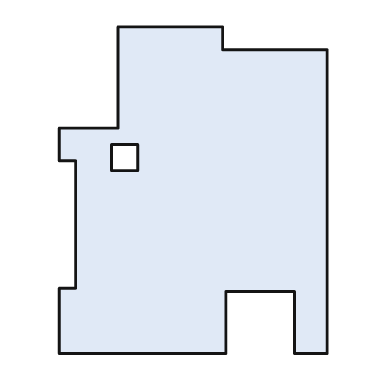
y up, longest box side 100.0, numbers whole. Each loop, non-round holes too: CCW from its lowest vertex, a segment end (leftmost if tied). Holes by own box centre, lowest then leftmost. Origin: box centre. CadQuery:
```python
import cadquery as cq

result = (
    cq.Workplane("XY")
    .moveTo(-41.0, -50.0)
    .lineTo(10.0, -50.0)
    .lineTo(10.0, -31.0)
    .lineTo(31.0, -31.0)
    .lineTo(31.0, -50.0)
    .lineTo(41.0, -50.0)
    .lineTo(41.0, 43.0)
    .lineTo(9.0, 43.0)
    .lineTo(9.0, 50.0)
    .lineTo(-23.0, 50.0)
    .lineTo(-23.0, 19.0)
    .lineTo(-41.0, 19.0)
    .lineTo(-41.0, 9.0)
    .lineTo(-36.0, 9.0)
    .lineTo(-36.0, -30.0)
    .lineTo(-41.0, -30.0)
    .close()
    .moveTo(-25.0, 6.0)
    .lineTo(-17.0, 6.0)
    .lineTo(-17.0, 14.0)
    .lineTo(-25.0, 14.0)
    .close()
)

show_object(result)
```